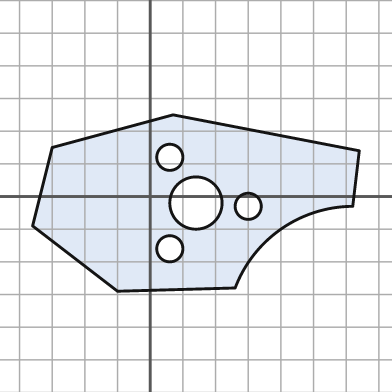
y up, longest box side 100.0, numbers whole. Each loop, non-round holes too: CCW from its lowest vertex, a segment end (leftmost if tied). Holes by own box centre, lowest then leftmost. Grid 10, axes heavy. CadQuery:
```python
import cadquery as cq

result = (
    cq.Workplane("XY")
    .moveTo(-10.0, -29.0)
    .lineTo(26.0, -28.0)
    .threePointArc((40.0, -10.0), (62.0, -3.0))
    .lineTo(64.0, 14.0)
    .lineTo(7.0, 25.0)
    .lineTo(-30.0, 15.0)
    .lineTo(-36.0, -9.0)
    .close()
    .moveTo(6.0, -16.0)
    .circle(4.0)
    .moveTo(30.0, -3.0)
    .circle(4.0)
    .moveTo(14.0, -2.0)
    .circle(8.0)
    .moveTo(6.0, 12.0)
    .circle(4.0)
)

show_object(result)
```